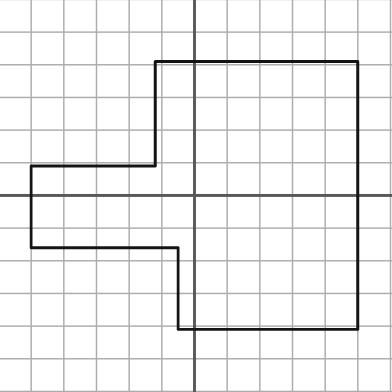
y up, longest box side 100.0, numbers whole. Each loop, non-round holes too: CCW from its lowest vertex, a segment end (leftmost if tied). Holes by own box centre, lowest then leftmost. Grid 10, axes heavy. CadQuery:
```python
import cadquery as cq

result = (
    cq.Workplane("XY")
    .moveTo(-5.0, -41.0)
    .lineTo(50.0, -41.0)
    .lineTo(50.0, 41.0)
    .lineTo(-12.0, 41.0)
    .lineTo(-12.0, 9.0)
    .lineTo(-50.0, 9.0)
    .lineTo(-50.0, -16.0)
    .lineTo(-5.0, -16.0)
    .close()
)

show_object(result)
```